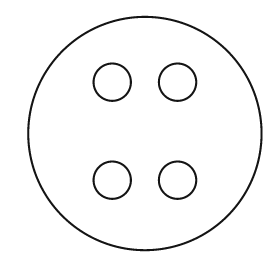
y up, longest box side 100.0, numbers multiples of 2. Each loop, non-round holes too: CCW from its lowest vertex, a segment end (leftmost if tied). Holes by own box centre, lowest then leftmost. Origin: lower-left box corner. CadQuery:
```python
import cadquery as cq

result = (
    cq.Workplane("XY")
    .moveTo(50.0, 50.0)
    .circle(50.0)
    .moveTo(36.0, 30.0)
    .circle(8.0)
    .moveTo(64.0, 30.0)
    .circle(8.0)
    .moveTo(36.0, 72.0)
    .circle(8.0)
    .moveTo(64.0, 72.0)
    .circle(8.0)
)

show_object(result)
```